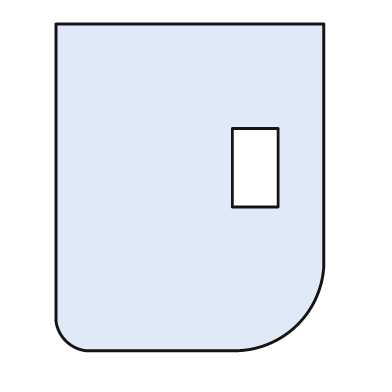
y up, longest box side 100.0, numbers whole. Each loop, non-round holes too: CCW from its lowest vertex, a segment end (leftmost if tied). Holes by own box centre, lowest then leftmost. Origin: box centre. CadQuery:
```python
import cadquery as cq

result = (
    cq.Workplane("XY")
    .moveTo(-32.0, -50.0)
    .lineTo(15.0, -50.0)
    .threePointArc((33.0, -42.0), (41.0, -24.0))
    .lineTo(41.0, 50.0)
    .lineTo(-41.0, 50.0)
    .lineTo(-41.0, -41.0)
    .threePointArc((-38.0, -47.0), (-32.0, -50.0))
    .close()
    .moveTo(13.0, -6.0)
    .lineTo(27.0, -6.0)
    .lineTo(27.0, 18.0)
    .lineTo(13.0, 18.0)
    .close()
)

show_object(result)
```